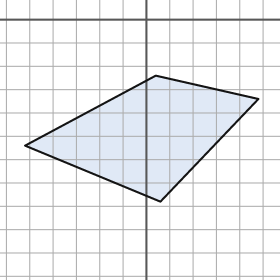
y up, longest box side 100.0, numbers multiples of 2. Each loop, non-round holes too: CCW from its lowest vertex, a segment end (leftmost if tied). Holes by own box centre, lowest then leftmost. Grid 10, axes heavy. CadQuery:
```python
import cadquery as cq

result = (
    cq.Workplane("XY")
    .moveTo(6.0, -78.0)
    .lineTo(48.0, -34.0)
    .lineTo(4.0, -24.0)
    .lineTo(-52.0, -54.0)
    .close()
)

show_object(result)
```